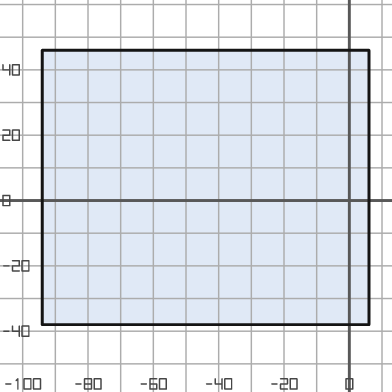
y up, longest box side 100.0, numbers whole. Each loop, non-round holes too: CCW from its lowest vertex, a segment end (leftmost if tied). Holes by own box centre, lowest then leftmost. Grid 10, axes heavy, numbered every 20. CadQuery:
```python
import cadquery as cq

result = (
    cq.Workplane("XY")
    .moveTo(-94.0, -38.0)
    .lineTo(6.0, -38.0)
    .lineTo(6.0, 46.0)
    .lineTo(-94.0, 46.0)
    .close()
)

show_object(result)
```